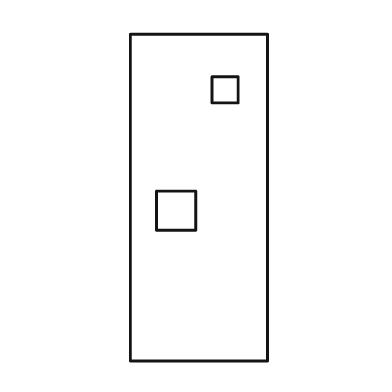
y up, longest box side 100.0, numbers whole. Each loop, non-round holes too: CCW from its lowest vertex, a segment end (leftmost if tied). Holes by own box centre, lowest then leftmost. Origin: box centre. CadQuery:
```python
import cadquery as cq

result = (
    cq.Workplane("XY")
    .moveTo(-21.0, -50.0)
    .lineTo(21.0, -50.0)
    .lineTo(21.0, 50.0)
    .lineTo(-21.0, 50.0)
    .close()
    .moveTo(-13.0, -10.0)
    .lineTo(-1.0, -10.0)
    .lineTo(-1.0, 2.0)
    .lineTo(-13.0, 2.0)
    .close()
    .moveTo(4.0, 29.0)
    .lineTo(12.0, 29.0)
    .lineTo(12.0, 37.0)
    .lineTo(4.0, 37.0)
    .close()
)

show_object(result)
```